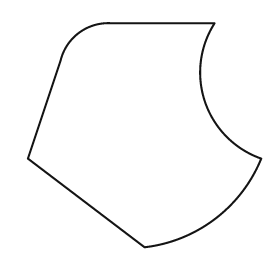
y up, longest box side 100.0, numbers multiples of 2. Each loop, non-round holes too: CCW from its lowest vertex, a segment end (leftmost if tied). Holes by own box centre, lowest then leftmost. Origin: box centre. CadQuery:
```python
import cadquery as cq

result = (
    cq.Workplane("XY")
    .moveTo(0.0, -48.0)
    .threePointArc((30.0, -36.0), (50.0, -10.0))
    .threePointArc((26.0, 14.0), (30.0, 48.0))
    .lineTo(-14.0, 48.0)
    .threePointArc((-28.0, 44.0), (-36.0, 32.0))
    .lineTo(-50.0, -10.0)
    .close()
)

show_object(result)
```